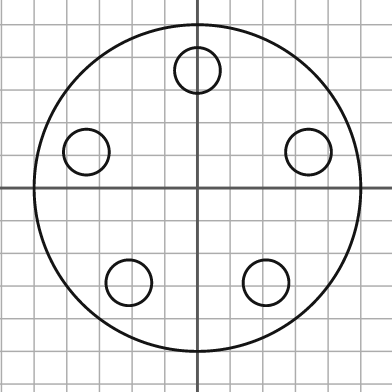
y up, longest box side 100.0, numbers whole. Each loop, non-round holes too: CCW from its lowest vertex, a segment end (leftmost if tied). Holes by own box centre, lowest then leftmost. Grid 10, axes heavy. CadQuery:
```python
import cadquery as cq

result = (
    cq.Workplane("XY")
    .moveTo(0.0, 0.0)
    .circle(50.0)
    .moveTo(-21.0, -29.0)
    .circle(7.0)
    .moveTo(21.0, -29.0)
    .circle(7.0)
    .moveTo(-34.0, 11.0)
    .circle(7.0)
    .moveTo(34.0, 11.0)
    .circle(7.0)
    .moveTo(0.0, 36.0)
    .circle(7.0)
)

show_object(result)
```